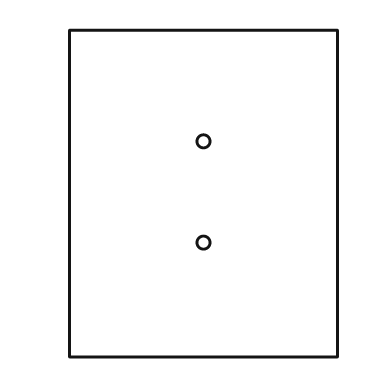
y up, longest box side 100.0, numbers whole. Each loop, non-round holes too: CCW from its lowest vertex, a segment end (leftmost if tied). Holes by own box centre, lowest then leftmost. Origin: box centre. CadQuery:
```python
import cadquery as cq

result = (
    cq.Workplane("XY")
    .moveTo(-41.0, -50.0)
    .lineTo(41.0, -50.0)
    .lineTo(41.0, 50.0)
    .lineTo(-41.0, 50.0)
    .close()
    .moveTo(0.0, -15.0)
    .circle(2.0)
    .moveTo(0.0, 16.0)
    .circle(2.0)
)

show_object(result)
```